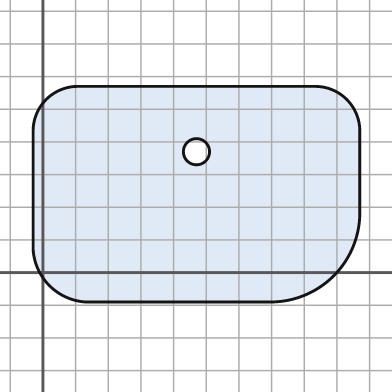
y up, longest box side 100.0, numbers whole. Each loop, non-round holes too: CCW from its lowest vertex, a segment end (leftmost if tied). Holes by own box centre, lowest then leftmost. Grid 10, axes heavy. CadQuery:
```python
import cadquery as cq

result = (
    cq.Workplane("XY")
    .moveTo(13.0, -9.0)
    .lineTo(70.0, -9.0)
    .threePointArc((89.0, -1.0), (97.0, 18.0))
    .lineTo(97.0, 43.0)
    .threePointArc((93.0, 53.0), (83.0, 57.0))
    .lineTo(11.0, 57.0)
    .threePointArc((1.0, 53.0), (-3.0, 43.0))
    .lineTo(-3.0, 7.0)
    .threePointArc((2.0, -4.0), (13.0, -9.0))
    .close()
    .moveTo(47.0, 37.0)
    .circle(4.0)
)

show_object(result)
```